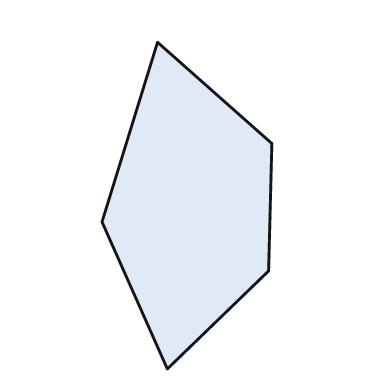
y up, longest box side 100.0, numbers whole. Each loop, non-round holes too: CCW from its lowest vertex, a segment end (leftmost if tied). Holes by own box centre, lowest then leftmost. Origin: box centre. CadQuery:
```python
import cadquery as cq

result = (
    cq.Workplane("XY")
    .moveTo(-6.0, -50.0)
    .lineTo(25.0, -20.0)
    .lineTo(26.0, 19.0)
    .lineTo(-9.0, 50.0)
    .lineTo(-26.0, -5.0)
    .close()
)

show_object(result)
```